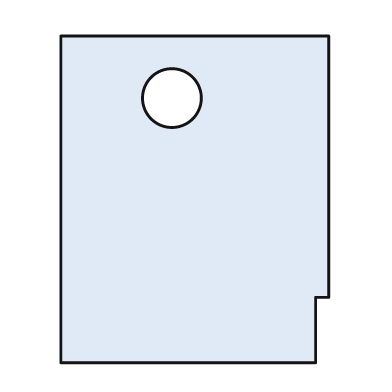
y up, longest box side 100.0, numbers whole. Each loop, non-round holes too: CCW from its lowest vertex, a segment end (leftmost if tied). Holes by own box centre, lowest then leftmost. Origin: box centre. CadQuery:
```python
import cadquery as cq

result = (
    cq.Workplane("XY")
    .moveTo(-41.0, -50.0)
    .lineTo(37.0, -50.0)
    .lineTo(37.0, -30.0)
    .lineTo(41.0, -30.0)
    .lineTo(41.0, 50.0)
    .lineTo(-41.0, 50.0)
    .close()
    .moveTo(-7.0, 31.0)
    .circle(9.0)
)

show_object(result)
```